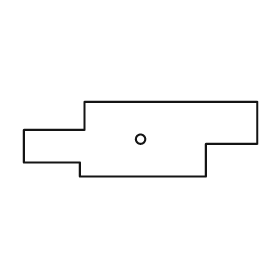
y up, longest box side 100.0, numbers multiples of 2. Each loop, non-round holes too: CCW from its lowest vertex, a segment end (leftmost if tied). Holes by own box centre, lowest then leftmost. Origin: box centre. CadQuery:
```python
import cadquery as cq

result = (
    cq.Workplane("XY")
    .moveTo(-26.0, -16.0)
    .lineTo(28.0, -16.0)
    .lineTo(28.0, -2.0)
    .lineTo(50.0, -2.0)
    .lineTo(50.0, 16.0)
    .lineTo(-24.0, 16.0)
    .lineTo(-24.0, 4.0)
    .lineTo(-50.0, 4.0)
    .lineTo(-50.0, -10.0)
    .lineTo(-26.0, -10.0)
    .close()
    .moveTo(0.0, 0.0)
    .circle(2.0)
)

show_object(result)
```